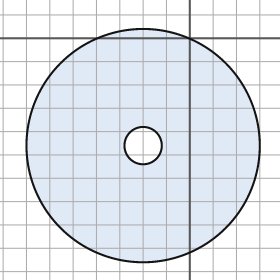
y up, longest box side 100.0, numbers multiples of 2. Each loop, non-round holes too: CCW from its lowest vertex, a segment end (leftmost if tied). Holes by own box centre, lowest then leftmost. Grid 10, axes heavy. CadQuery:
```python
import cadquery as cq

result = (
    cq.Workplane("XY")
    .moveTo(-20.0, -46.0)
    .circle(50.0)
    .moveTo(-20.0, -46.0)
    .circle(8.0)
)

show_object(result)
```